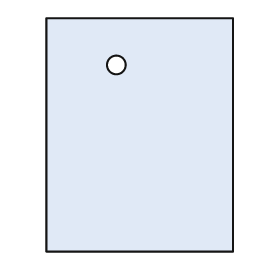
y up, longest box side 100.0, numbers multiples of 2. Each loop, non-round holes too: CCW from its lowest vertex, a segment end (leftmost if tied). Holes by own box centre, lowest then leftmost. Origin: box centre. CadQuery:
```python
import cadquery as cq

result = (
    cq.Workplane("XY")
    .moveTo(-40.0, -50.0)
    .lineTo(40.0, -50.0)
    .lineTo(40.0, 50.0)
    .lineTo(-40.0, 50.0)
    .close()
    .moveTo(-10.0, 30.0)
    .circle(4.0)
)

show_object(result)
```